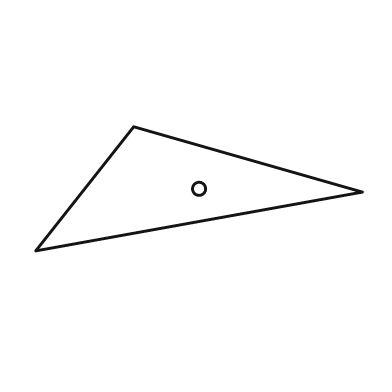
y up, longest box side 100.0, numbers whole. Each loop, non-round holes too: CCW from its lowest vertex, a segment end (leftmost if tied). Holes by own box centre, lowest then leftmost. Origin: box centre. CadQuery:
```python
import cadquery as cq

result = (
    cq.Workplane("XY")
    .moveTo(-50.0, -19.0)
    .lineTo(50.0, -1.0)
    .lineTo(-20.0, 19.0)
    .close()
    .moveTo(0.0, 0.0)
    .circle(2.0)
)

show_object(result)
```